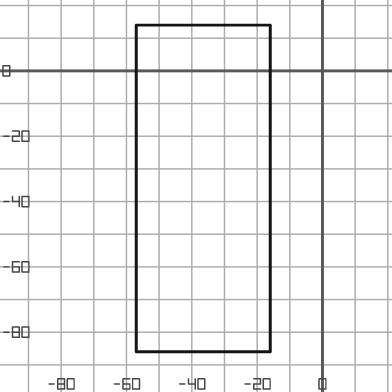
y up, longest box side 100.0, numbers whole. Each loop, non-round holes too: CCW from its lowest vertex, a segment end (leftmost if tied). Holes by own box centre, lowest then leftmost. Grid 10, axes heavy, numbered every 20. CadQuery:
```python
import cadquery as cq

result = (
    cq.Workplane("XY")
    .moveTo(-57.0, -86.0)
    .lineTo(-16.0, -86.0)
    .lineTo(-16.0, 14.0)
    .lineTo(-57.0, 14.0)
    .close()
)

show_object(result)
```